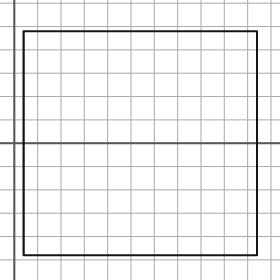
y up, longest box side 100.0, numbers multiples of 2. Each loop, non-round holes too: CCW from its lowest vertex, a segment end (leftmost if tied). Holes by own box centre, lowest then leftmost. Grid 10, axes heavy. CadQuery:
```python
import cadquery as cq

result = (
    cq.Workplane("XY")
    .moveTo(4.0, -48.0)
    .lineTo(104.0, -48.0)
    .lineTo(104.0, 48.0)
    .lineTo(4.0, 48.0)
    .close()
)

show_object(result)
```